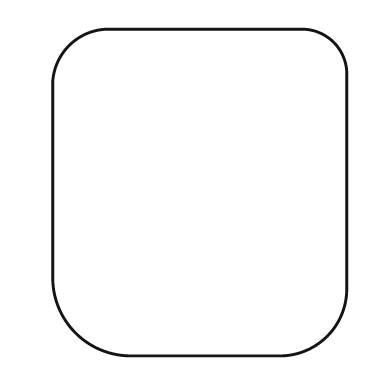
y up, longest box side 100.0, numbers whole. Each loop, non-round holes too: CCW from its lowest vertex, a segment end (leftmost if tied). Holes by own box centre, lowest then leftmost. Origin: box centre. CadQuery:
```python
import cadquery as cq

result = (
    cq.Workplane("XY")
    .moveTo(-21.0, -50.0)
    .lineTo(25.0, -50.0)
    .threePointArc((39.0, -44.0), (45.0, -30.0))
    .lineTo(45.0, 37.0)
    .threePointArc((41.0, 46.0), (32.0, 50.0))
    .lineTo(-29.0, 50.0)
    .threePointArc((-40.0, 45.0), (-45.0, 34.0))
    .lineTo(-45.0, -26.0)
    .threePointArc((-38.0, -43.0), (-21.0, -50.0))
    .close()
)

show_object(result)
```